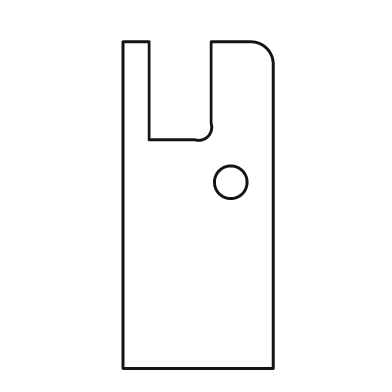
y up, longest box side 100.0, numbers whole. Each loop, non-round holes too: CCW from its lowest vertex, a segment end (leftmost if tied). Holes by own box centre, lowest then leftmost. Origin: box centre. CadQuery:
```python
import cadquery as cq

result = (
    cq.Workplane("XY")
    .moveTo(-23.0, -50.0)
    .lineTo(23.0, -50.0)
    .lineTo(23.0, 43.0)
    .threePointArc((21.0, 48.0), (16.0, 50.0))
    .lineTo(4.0, 50.0)
    .lineTo(4.0, 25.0)
    .threePointArc((3.0, 21.0), (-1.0, 20.0))
    .lineTo(-15.0, 20.0)
    .lineTo(-15.0, 50.0)
    .lineTo(-23.0, 50.0)
    .close()
    .moveTo(10.0, 7.0)
    .circle(5.0)
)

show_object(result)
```